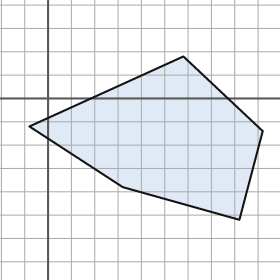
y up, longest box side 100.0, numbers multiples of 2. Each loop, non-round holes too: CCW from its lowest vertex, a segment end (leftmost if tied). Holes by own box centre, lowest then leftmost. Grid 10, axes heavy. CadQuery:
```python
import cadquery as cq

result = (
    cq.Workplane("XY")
    .moveTo(82.0, -52.0)
    .lineTo(92.0, -14.0)
    .lineTo(58.0, 18.0)
    .lineTo(-8.0, -12.0)
    .lineTo(32.0, -38.0)
    .close()
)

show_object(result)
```